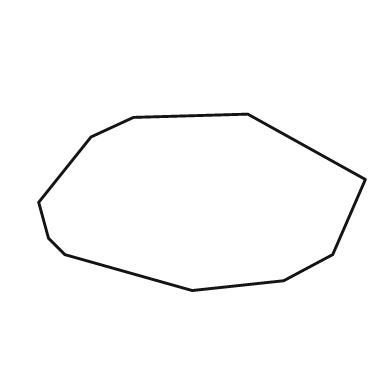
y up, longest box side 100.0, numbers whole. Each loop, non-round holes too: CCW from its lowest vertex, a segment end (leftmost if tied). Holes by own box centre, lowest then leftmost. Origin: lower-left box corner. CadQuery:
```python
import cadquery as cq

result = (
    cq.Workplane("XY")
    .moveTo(47.0, 0.0)
    .lineTo(75.0, 3.0)
    .lineTo(90.0, 11.0)
    .lineTo(100.0, 34.0)
    .lineTo(64.0, 54.0)
    .lineTo(29.0, 53.0)
    .lineTo(16.0, 47.0)
    .lineTo(0.0, 27.0)
    .lineTo(3.0, 16.0)
    .lineTo(8.0, 11.0)
    .close()
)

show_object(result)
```